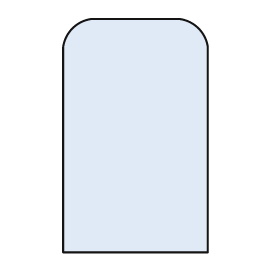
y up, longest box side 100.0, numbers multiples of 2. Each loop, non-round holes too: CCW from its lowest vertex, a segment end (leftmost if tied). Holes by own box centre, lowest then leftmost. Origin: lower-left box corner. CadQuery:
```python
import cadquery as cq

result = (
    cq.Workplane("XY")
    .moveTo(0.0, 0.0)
    .lineTo(62.0, 0.0)
    .lineTo(62.0, 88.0)
    .threePointArc((58.0, 96.0), (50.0, 100.0))
    .lineTo(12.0, 100.0)
    .threePointArc((4.0, 96.0), (0.0, 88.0))
    .close()
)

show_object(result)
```